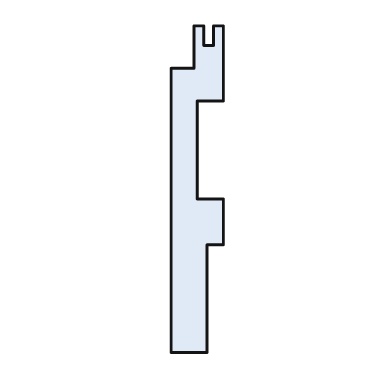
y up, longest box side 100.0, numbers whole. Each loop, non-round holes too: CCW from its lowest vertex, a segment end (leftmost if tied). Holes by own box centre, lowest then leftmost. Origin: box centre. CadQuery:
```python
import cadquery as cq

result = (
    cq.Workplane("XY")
    .moveTo(-8.0, -50.0)
    .lineTo(3.0, -50.0)
    .lineTo(3.0, -17.0)
    .lineTo(8.0, -17.0)
    .lineTo(8.0, -3.0)
    .lineTo(0.0, -3.0)
    .lineTo(0.0, 27.0)
    .lineTo(8.0, 27.0)
    .lineTo(8.0, 50.0)
    .lineTo(5.0, 50.0)
    .lineTo(5.0, 44.0)
    .lineTo(2.0, 44.0)
    .lineTo(2.0, 50.0)
    .lineTo(-1.0, 50.0)
    .lineTo(-1.0, 37.0)
    .lineTo(-8.0, 37.0)
    .close()
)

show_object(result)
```